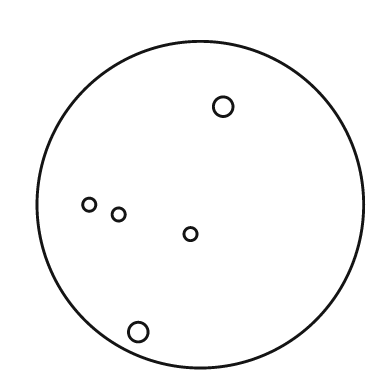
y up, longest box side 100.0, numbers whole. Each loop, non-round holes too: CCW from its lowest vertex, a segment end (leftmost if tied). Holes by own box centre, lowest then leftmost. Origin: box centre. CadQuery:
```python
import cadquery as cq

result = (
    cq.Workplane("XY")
    .moveTo(0.0, 0.0)
    .circle(50.0)
    .moveTo(-19.0, -39.0)
    .circle(3.0)
    .moveTo(-3.0, -9.0)
    .circle(2.0)
    .moveTo(-25.0, -3.0)
    .circle(2.0)
    .moveTo(-34.0, 0.0)
    .circle(2.0)
    .moveTo(7.0, 30.0)
    .circle(3.0)
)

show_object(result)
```